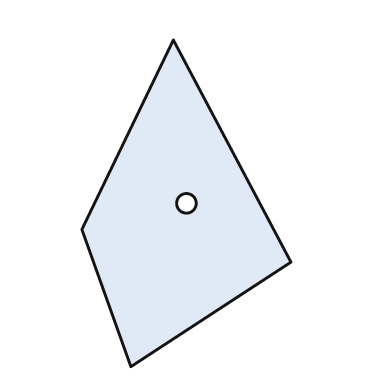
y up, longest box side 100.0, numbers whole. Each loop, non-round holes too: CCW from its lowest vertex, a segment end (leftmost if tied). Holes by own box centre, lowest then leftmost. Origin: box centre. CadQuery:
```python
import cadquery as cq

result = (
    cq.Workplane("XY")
    .moveTo(-17.0, -50.0)
    .lineTo(32.0, -18.0)
    .lineTo(-4.0, 50.0)
    .lineTo(-32.0, -8.0)
    .close()
    .moveTo(0.0, 0.0)
    .circle(3.0)
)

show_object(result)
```